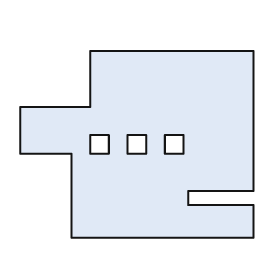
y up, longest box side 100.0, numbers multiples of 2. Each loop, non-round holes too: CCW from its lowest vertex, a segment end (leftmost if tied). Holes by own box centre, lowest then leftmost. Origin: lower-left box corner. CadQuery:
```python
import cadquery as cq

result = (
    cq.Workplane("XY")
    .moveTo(22.0, 0.0)
    .lineTo(100.0, 0.0)
    .lineTo(100.0, 14.0)
    .lineTo(72.0, 14.0)
    .lineTo(72.0, 20.0)
    .lineTo(100.0, 20.0)
    .lineTo(100.0, 80.0)
    .lineTo(30.0, 80.0)
    .lineTo(30.0, 56.0)
    .lineTo(0.0, 56.0)
    .lineTo(0.0, 36.0)
    .lineTo(22.0, 36.0)
    .close()
    .moveTo(30.0, 36.0)
    .lineTo(38.0, 36.0)
    .lineTo(38.0, 44.0)
    .lineTo(30.0, 44.0)
    .close()
    .moveTo(46.0, 36.0)
    .lineTo(54.0, 36.0)
    .lineTo(54.0, 44.0)
    .lineTo(46.0, 44.0)
    .close()
    .moveTo(62.0, 36.0)
    .lineTo(70.0, 36.0)
    .lineTo(70.0, 44.0)
    .lineTo(62.0, 44.0)
    .close()
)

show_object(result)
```